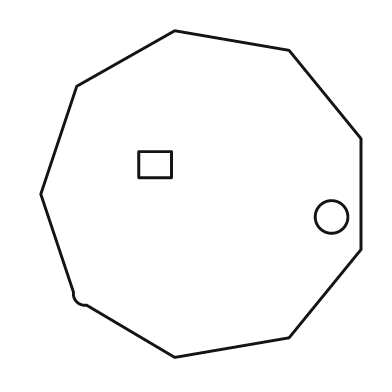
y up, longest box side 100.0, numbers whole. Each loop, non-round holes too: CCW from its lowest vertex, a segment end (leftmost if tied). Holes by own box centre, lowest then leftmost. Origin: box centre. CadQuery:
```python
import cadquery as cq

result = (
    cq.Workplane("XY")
    .moveTo(-8.0, -50.0)
    .lineTo(27.0, -44.0)
    .lineTo(49.0, -17.0)
    .lineTo(49.0, 17.0)
    .lineTo(27.0, 44.0)
    .lineTo(-8.0, 50.0)
    .lineTo(-38.0, 33.0)
    .lineTo(-49.0, 0.0)
    .lineTo(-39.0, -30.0)
    .threePointArc((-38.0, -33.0), (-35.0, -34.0))
    .close()
    .moveTo(40.0, -7.0)
    .circle(5.0)
    .moveTo(-19.0, 5.0)
    .lineTo(-9.0, 5.0)
    .lineTo(-9.0, 13.0)
    .lineTo(-19.0, 13.0)
    .close()
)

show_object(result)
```